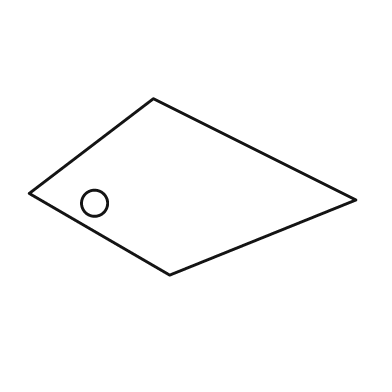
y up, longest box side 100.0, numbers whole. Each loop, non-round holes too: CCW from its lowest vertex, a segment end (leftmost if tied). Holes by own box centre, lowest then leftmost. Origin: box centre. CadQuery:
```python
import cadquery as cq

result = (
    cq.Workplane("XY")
    .moveTo(-7.0, -27.0)
    .lineTo(50.0, -4.0)
    .lineTo(-12.0, 27.0)
    .lineTo(-50.0, -2.0)
    .close()
    .moveTo(-30.0, -5.0)
    .circle(4.0)
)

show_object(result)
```